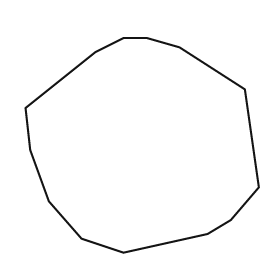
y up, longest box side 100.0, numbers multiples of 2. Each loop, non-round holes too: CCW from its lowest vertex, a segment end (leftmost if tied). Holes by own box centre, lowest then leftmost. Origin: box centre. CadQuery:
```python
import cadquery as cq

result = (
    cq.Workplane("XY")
    .moveTo(-8.0, -46.0)
    .lineTo(28.0, -38.0)
    .lineTo(38.0, -32.0)
    .lineTo(50.0, -18.0)
    .lineTo(44.0, 24.0)
    .lineTo(16.0, 42.0)
    .lineTo(2.0, 46.0)
    .lineTo(-8.0, 46.0)
    .lineTo(-20.0, 40.0)
    .lineTo(-50.0, 16.0)
    .lineTo(-48.0, -2.0)
    .lineTo(-40.0, -24.0)
    .lineTo(-26.0, -40.0)
    .close()
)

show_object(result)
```